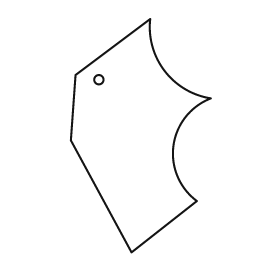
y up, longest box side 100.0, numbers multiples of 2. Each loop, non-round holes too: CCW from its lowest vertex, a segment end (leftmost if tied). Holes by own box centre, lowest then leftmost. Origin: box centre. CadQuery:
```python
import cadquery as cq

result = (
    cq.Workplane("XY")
    .moveTo(-4.0, -50.0)
    .lineTo(24.0, -28.0)
    .threePointArc((14.0, -4.0), (30.0, 16.0))
    .threePointArc((10.0, 28.0), (4.0, 50.0))
    .lineTo(-28.0, 26.0)
    .lineTo(-30.0, -2.0)
    .close()
    .moveTo(-18.0, 24.0)
    .circle(2.0)
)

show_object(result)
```